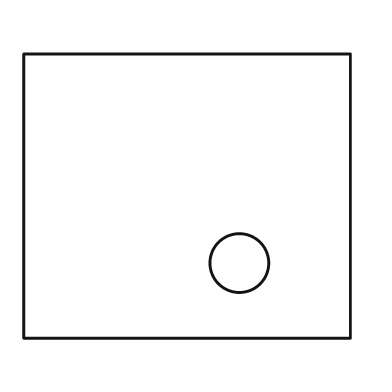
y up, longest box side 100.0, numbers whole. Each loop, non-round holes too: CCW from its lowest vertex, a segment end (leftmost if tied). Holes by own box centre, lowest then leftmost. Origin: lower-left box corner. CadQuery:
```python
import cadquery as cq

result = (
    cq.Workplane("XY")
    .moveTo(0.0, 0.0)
    .lineTo(100.0, 0.0)
    .lineTo(100.0, 87.0)
    .lineTo(0.0, 87.0)
    .close()
    .moveTo(66.0, 23.0)
    .circle(9.0)
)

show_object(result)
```